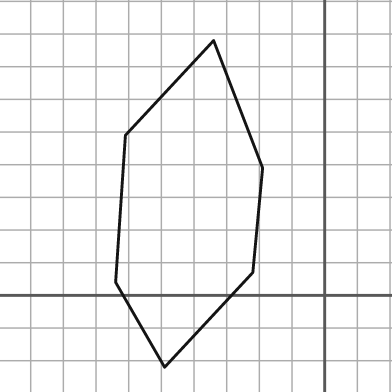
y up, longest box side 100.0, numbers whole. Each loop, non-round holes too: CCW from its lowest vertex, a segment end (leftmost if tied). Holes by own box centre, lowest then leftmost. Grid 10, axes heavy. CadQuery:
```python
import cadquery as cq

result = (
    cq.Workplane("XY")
    .moveTo(-49.0, -22.0)
    .lineTo(-22.0, 7.0)
    .lineTo(-19.0, 39.0)
    .lineTo(-34.0, 78.0)
    .lineTo(-61.0, 49.0)
    .lineTo(-64.0, 4.0)
    .close()
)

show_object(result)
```